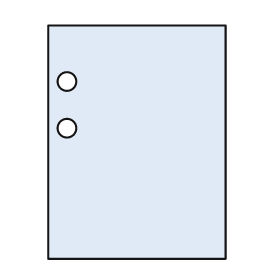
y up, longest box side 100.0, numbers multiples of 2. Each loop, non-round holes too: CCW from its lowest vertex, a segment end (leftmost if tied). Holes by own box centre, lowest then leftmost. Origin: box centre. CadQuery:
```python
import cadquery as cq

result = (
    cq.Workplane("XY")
    .moveTo(-38.0, -50.0)
    .lineTo(38.0, -50.0)
    .lineTo(38.0, 50.0)
    .lineTo(-38.0, 50.0)
    .close()
    .moveTo(-30.0, 6.0)
    .circle(4.0)
    .moveTo(-30.0, 26.0)
    .circle(4.0)
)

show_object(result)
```